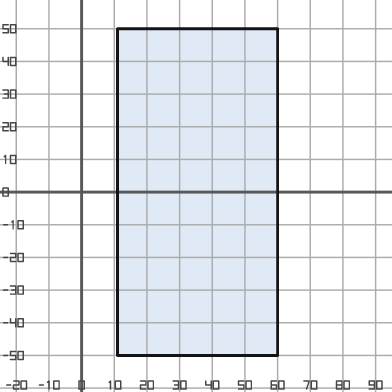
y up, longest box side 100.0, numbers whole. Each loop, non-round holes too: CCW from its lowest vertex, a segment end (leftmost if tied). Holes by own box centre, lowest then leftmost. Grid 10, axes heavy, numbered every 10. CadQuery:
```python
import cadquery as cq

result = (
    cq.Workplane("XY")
    .moveTo(11.0, -50.0)
    .lineTo(60.0, -50.0)
    .lineTo(60.0, 50.0)
    .lineTo(11.0, 50.0)
    .close()
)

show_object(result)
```